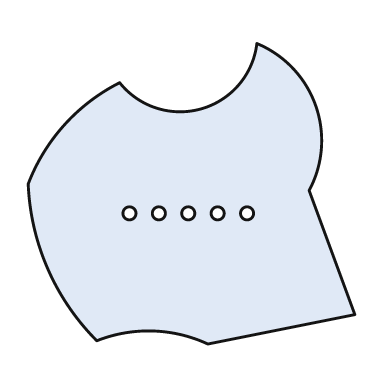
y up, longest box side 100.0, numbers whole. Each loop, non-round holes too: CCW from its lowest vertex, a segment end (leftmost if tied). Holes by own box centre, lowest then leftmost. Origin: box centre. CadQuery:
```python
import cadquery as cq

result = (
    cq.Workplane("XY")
    .moveTo(5.0, -46.0)
    .lineTo(50.0, -37.0)
    .lineTo(36.0, 1.0)
    .threePointArc((38.0, 27.0), (20.0, 46.0))
    .threePointArc((3.0, 26.0), (-22.0, 34.0))
    .threePointArc((-39.0, 21.0), (-50.0, 3.0))
    .threePointArc((-44.0, -23.0), (-29.0, -45.0))
    .threePointArc((-12.0, -42.0), (5.0, -46.0))
    .close()
    .moveTo(-19.0, -6.0)
    .circle(2.0)
    .moveTo(-10.0, -6.0)
    .circle(2.0)
    .moveTo(-1.0, -6.0)
    .circle(2.0)
    .moveTo(8.0, -6.0)
    .circle(2.0)
    .moveTo(17.0, -6.0)
    .circle(2.0)
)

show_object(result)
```